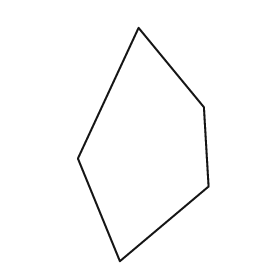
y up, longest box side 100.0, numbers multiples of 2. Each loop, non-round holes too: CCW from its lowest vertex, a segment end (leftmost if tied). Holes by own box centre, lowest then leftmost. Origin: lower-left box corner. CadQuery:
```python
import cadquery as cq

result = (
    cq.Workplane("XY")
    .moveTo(18.0, 0.0)
    .lineTo(56.0, 32.0)
    .lineTo(54.0, 66.0)
    .lineTo(26.0, 100.0)
    .lineTo(0.0, 44.0)
    .close()
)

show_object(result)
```